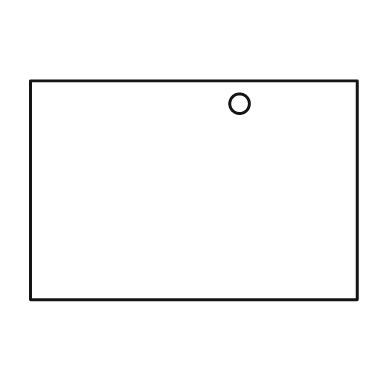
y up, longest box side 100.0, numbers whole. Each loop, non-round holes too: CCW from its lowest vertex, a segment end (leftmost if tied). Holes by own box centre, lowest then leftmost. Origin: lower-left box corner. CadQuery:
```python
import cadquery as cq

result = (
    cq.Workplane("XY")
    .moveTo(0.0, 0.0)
    .lineTo(100.0, 0.0)
    .lineTo(100.0, 67.0)
    .lineTo(0.0, 67.0)
    .close()
    .moveTo(64.0, 60.0)
    .circle(3.0)
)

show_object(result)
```